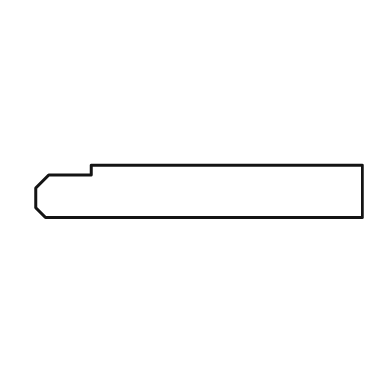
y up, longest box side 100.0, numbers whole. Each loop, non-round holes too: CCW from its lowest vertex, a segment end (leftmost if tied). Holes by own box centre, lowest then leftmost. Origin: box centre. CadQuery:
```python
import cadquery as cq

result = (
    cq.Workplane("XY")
    .moveTo(-47.0, -8.0)
    .lineTo(50.0, -8.0)
    .lineTo(50.0, 8.0)
    .lineTo(-33.0, 8.0)
    .lineTo(-33.0, 5.0)
    .lineTo(-46.0, 5.0)
    .lineTo(-50.0, 1.0)
    .lineTo(-50.0, -5.0)
    .close()
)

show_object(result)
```